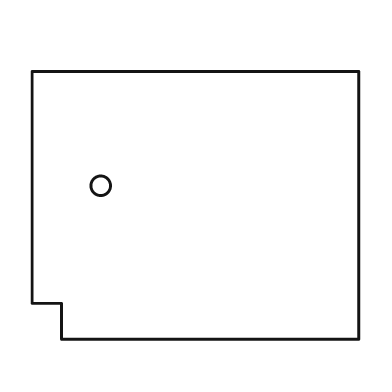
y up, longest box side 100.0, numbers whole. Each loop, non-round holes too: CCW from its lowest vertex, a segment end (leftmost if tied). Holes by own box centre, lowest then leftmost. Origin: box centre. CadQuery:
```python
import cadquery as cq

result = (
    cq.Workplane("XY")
    .moveTo(-41.0, -41.0)
    .lineTo(50.0, -41.0)
    .lineTo(50.0, 41.0)
    .lineTo(-50.0, 41.0)
    .lineTo(-50.0, -30.0)
    .lineTo(-41.0, -30.0)
    .close()
    .moveTo(-29.0, 6.0)
    .circle(3.0)
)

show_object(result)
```